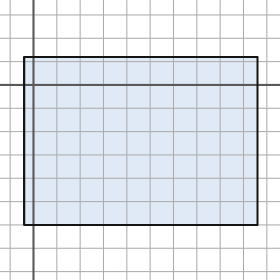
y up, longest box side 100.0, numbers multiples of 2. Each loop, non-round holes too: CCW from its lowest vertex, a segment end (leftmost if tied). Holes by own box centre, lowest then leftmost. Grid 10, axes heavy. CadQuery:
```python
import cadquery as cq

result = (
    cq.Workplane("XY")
    .moveTo(-4.0, -60.0)
    .lineTo(96.0, -60.0)
    .lineTo(96.0, 12.0)
    .lineTo(-4.0, 12.0)
    .close()
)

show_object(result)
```